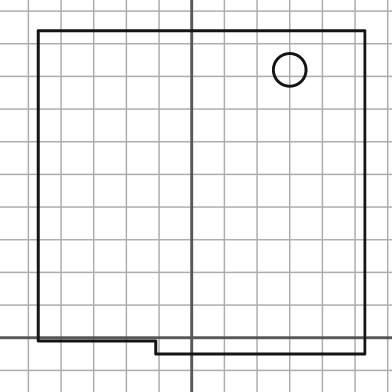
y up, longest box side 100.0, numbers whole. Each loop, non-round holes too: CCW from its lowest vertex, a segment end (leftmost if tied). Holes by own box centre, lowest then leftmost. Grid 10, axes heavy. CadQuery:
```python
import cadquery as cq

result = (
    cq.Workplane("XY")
    .moveTo(-11.0, -5.0)
    .lineTo(53.0, -5.0)
    .lineTo(53.0, 94.0)
    .lineTo(-47.0, 94.0)
    .lineTo(-47.0, -1.0)
    .lineTo(-11.0, -1.0)
    .close()
    .moveTo(30.0, 82.0)
    .circle(5.0)
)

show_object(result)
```